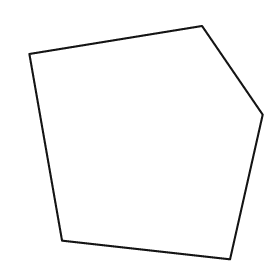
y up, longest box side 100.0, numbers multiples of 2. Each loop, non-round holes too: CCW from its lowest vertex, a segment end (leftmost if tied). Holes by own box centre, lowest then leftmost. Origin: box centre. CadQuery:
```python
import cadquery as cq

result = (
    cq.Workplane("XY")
    .moveTo(36.0, -50.0)
    .lineTo(50.0, 12.0)
    .lineTo(24.0, 50.0)
    .lineTo(-50.0, 38.0)
    .lineTo(-36.0, -42.0)
    .close()
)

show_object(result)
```